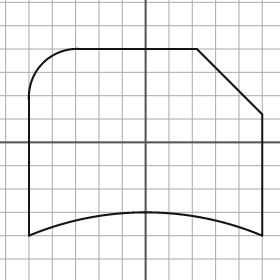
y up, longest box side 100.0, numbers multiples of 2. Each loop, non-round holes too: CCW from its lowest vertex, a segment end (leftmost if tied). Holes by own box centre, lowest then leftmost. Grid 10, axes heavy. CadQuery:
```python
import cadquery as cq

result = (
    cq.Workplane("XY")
    .moveTo(-50.0, -40.0)
    .threePointArc((0.0, -30.0), (50.0, -40.0))
    .lineTo(50.0, 12.0)
    .lineTo(22.0, 40.0)
    .lineTo(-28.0, 40.0)
    .threePointArc((-44.0, 34.0), (-50.0, 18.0))
    .close()
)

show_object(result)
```